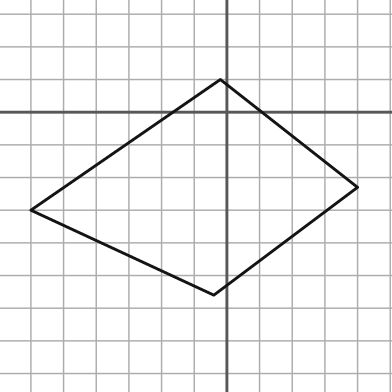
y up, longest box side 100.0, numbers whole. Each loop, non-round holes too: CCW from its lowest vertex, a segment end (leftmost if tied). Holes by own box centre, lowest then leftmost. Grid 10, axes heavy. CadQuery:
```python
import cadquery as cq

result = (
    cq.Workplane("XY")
    .moveTo(-4.0, -56.0)
    .lineTo(40.0, -23.0)
    .lineTo(-2.0, 10.0)
    .lineTo(-60.0, -30.0)
    .close()
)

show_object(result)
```